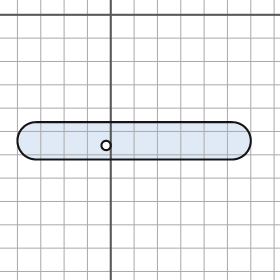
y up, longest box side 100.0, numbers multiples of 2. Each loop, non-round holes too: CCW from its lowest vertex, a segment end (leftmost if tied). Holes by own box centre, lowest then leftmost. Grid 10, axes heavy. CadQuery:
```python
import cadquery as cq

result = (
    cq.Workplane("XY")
    .moveTo(-32.0, -62.0)
    .lineTo(52.0, -62.0)
    .threePointArc((60.0, -54.0), (52.0, -46.0))
    .lineTo(-32.0, -46.0)
    .threePointArc((-40.0, -54.0), (-32.0, -62.0))
    .close()
    .moveTo(-2.0, -56.0)
    .circle(2.0)
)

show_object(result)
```